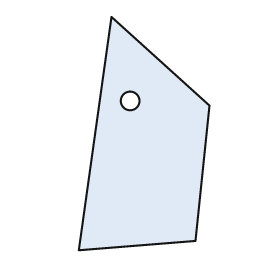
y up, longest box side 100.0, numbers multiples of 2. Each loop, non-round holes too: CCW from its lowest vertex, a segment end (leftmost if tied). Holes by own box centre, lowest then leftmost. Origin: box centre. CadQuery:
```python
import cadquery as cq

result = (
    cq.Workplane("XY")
    .moveTo(-28.0, -50.0)
    .lineTo(22.0, -46.0)
    .lineTo(28.0, 12.0)
    .lineTo(-14.0, 50.0)
    .close()
    .moveTo(-6.0, 14.0)
    .circle(4.0)
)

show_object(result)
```